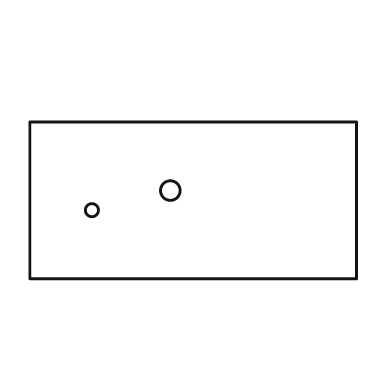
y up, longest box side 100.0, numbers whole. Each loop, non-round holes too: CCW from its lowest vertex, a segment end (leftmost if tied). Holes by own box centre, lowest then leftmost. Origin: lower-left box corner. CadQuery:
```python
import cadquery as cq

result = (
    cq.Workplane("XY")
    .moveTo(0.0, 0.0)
    .lineTo(100.0, 0.0)
    .lineTo(100.0, 48.0)
    .lineTo(0.0, 48.0)
    .close()
    .moveTo(19.0, 21.0)
    .circle(2.0)
    .moveTo(43.0, 27.0)
    .circle(3.0)
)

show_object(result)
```